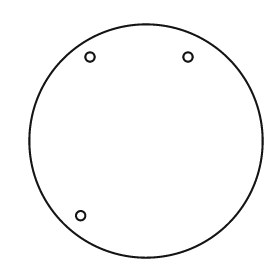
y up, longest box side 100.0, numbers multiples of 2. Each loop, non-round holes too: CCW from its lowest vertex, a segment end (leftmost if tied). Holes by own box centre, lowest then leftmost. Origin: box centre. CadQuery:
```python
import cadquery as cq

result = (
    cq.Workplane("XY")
    .moveTo(0.0, 0.0)
    .circle(50.0)
    .moveTo(-28.0, -32.0)
    .circle(2.0)
    .moveTo(-24.0, 36.0)
    .circle(2.0)
    .moveTo(18.0, 36.0)
    .circle(2.0)
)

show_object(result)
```